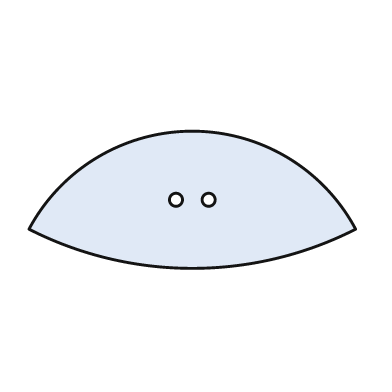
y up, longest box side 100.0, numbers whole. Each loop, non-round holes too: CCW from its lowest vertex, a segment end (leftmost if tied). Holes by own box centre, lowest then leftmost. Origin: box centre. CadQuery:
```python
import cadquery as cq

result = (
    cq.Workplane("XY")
    .moveTo(-50.0, -9.0)
    .threePointArc((0.0, -21.0), (50.0, -9.0))
    .threePointArc((0.0, 21.0), (-50.0, -9.0))
    .close()
    .moveTo(-5.0, 0.0)
    .circle(2.0)
    .moveTo(5.0, 0.0)
    .circle(2.0)
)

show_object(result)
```